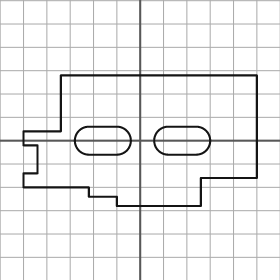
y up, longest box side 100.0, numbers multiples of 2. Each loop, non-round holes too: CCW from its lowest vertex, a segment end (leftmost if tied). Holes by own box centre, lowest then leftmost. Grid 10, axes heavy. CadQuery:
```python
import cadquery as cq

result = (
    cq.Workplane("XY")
    .moveTo(-10.0, -28.0)
    .lineTo(26.0, -28.0)
    .lineTo(26.0, -16.0)
    .lineTo(50.0, -16.0)
    .lineTo(50.0, 28.0)
    .lineTo(-34.0, 28.0)
    .lineTo(-34.0, 4.0)
    .lineTo(-50.0, 4.0)
    .lineTo(-50.0, -2.0)
    .lineTo(-44.0, -2.0)
    .lineTo(-44.0, -14.0)
    .lineTo(-50.0, -14.0)
    .lineTo(-50.0, -20.0)
    .lineTo(-22.0, -20.0)
    .lineTo(-22.0, -24.0)
    .lineTo(-10.0, -24.0)
    .close()
    .moveTo(-22.0, -6.0)
    .lineTo(-10.0, -6.0)
    .threePointArc((-4.0, 0.0), (-10.0, 6.0))
    .lineTo(-22.0, 6.0)
    .threePointArc((-28.0, 0.0), (-22.0, -6.0))
    .close()
    .moveTo(12.0, -6.0)
    .lineTo(24.0, -6.0)
    .threePointArc((30.0, 0.0), (24.0, 6.0))
    .lineTo(12.0, 6.0)
    .threePointArc((6.0, 0.0), (12.0, -6.0))
    .close()
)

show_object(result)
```